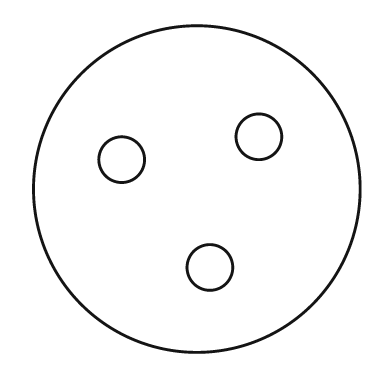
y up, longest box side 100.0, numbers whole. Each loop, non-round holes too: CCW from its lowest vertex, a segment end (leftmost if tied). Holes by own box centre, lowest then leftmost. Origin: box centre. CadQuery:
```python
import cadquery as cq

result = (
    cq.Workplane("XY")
    .moveTo(0.0, 0.0)
    .circle(50.0)
    .moveTo(4.0, -24.0)
    .circle(7.0)
    .moveTo(-23.0, 9.0)
    .circle(7.0)
    .moveTo(19.0, 16.0)
    .circle(7.0)
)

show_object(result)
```